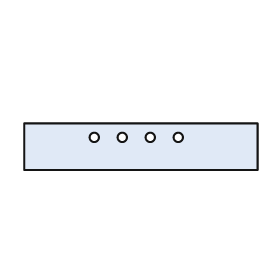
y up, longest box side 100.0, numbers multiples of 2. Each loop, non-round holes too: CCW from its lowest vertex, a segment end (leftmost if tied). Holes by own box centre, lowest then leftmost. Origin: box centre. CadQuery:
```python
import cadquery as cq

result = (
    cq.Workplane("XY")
    .moveTo(-50.0, -10.0)
    .lineTo(50.0, -10.0)
    .lineTo(50.0, 10.0)
    .lineTo(-50.0, 10.0)
    .close()
    .moveTo(-20.0, 4.0)
    .circle(2.0)
    .moveTo(-8.0, 4.0)
    .circle(2.0)
    .moveTo(4.0, 4.0)
    .circle(2.0)
    .moveTo(16.0, 4.0)
    .circle(2.0)
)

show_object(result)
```